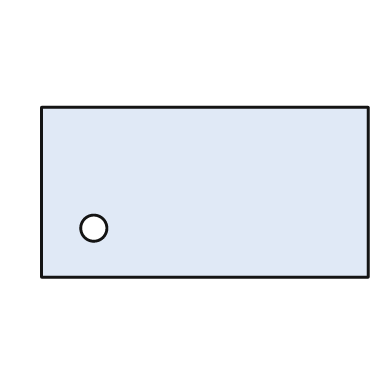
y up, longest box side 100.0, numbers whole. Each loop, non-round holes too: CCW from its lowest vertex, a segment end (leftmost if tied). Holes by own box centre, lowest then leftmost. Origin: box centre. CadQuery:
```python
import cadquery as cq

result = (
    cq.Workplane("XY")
    .moveTo(-50.0, -26.0)
    .lineTo(50.0, -26.0)
    .lineTo(50.0, 26.0)
    .lineTo(-50.0, 26.0)
    .close()
    .moveTo(-34.0, -11.0)
    .circle(4.0)
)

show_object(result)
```